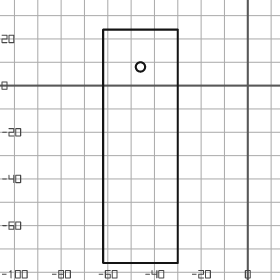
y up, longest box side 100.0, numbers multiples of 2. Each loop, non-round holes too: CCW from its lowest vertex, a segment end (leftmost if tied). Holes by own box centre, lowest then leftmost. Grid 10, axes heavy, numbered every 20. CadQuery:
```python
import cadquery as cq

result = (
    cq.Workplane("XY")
    .moveTo(-62.0, -76.0)
    .lineTo(-30.0, -76.0)
    .lineTo(-30.0, 24.0)
    .lineTo(-62.0, 24.0)
    .close()
    .moveTo(-46.0, 8.0)
    .circle(2.0)
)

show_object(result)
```